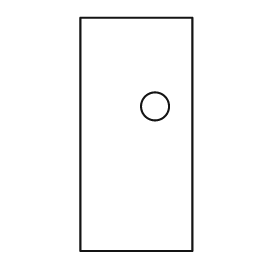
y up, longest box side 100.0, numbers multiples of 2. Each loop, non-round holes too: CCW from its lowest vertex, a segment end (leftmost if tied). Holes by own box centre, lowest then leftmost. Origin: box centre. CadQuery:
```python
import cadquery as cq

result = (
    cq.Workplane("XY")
    .moveTo(-24.0, -50.0)
    .lineTo(24.0, -50.0)
    .lineTo(24.0, 50.0)
    .lineTo(-24.0, 50.0)
    .close()
    .moveTo(8.0, 12.0)
    .circle(6.0)
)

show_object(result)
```